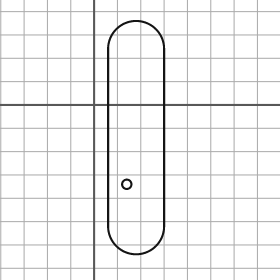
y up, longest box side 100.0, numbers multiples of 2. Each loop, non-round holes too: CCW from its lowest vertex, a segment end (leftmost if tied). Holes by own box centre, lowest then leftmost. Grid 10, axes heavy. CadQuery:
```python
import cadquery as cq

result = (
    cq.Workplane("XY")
    .moveTo(6.0, -52.0)
    .threePointArc((18.0, -64.0), (30.0, -52.0))
    .lineTo(30.0, 24.0)
    .threePointArc((18.0, 36.0), (6.0, 24.0))
    .close()
    .moveTo(14.0, -34.0)
    .circle(2.0)
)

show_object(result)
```